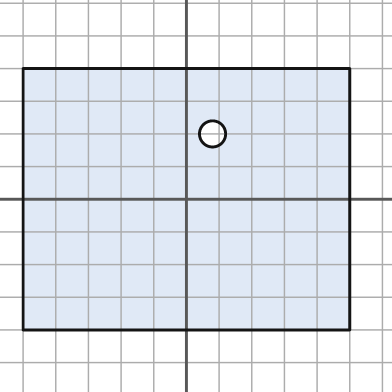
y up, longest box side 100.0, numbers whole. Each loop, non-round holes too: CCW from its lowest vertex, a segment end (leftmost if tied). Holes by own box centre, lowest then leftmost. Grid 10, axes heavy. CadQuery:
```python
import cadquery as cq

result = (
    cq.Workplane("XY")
    .moveTo(-50.0, -40.0)
    .lineTo(50.0, -40.0)
    .lineTo(50.0, 40.0)
    .lineTo(-50.0, 40.0)
    .close()
    .moveTo(8.0, 20.0)
    .circle(4.0)
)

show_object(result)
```